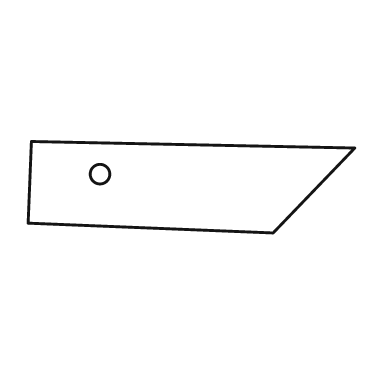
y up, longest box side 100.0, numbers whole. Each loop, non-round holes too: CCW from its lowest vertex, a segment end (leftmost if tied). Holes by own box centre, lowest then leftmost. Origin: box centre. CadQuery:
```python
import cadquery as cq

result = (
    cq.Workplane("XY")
    .moveTo(25.0, -14.0)
    .lineTo(50.0, 12.0)
    .lineTo(-49.0, 14.0)
    .lineTo(-50.0, -11.0)
    .close()
    .moveTo(-28.0, 4.0)
    .circle(3.0)
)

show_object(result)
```